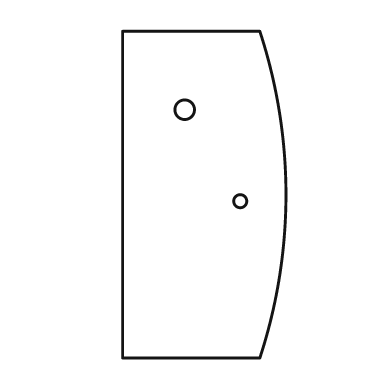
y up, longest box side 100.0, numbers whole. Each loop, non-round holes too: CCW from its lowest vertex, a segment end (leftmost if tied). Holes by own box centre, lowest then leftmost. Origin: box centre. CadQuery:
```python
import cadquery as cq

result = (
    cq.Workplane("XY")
    .moveTo(-25.0, -50.0)
    .lineTo(17.0, -50.0)
    .threePointArc((25.0, 0.0), (17.0, 50.0))
    .lineTo(-25.0, 50.0)
    .close()
    .moveTo(11.0, -2.0)
    .circle(2.0)
    .moveTo(-6.0, 26.0)
    .circle(3.0)
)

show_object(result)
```